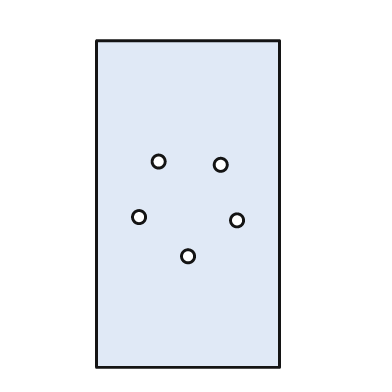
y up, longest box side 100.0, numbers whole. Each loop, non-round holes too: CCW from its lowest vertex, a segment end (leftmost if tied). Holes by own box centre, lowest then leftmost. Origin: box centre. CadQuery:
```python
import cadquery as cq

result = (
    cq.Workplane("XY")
    .moveTo(-28.0, -50.0)
    .lineTo(28.0, -50.0)
    .lineTo(28.0, 50.0)
    .lineTo(-28.0, 50.0)
    .close()
    .moveTo(0.0, -16.0)
    .circle(2.0)
    .moveTo(15.0, -5.0)
    .circle(2.0)
    .moveTo(-15.0, -4.0)
    .circle(2.0)
    .moveTo(10.0, 12.0)
    .circle(2.0)
    .moveTo(-9.0, 13.0)
    .circle(2.0)
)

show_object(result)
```